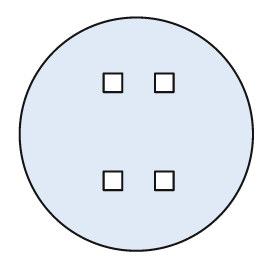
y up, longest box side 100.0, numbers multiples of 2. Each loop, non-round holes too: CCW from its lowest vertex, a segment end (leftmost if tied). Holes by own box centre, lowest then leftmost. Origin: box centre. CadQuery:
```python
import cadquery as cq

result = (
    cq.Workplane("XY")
    .moveTo(0.0, 0.0)
    .circle(50.0)
    .moveTo(-14.0, -24.0)
    .lineTo(-6.0, -24.0)
    .lineTo(-6.0, -16.0)
    .lineTo(-14.0, -16.0)
    .close()
    .moveTo(8.0, -24.0)
    .lineTo(16.0, -24.0)
    .lineTo(16.0, -16.0)
    .lineTo(8.0, -16.0)
    .close()
    .moveTo(-14.0, 18.0)
    .lineTo(-6.0, 18.0)
    .lineTo(-6.0, 26.0)
    .lineTo(-14.0, 26.0)
    .close()
    .moveTo(8.0, 18.0)
    .lineTo(16.0, 18.0)
    .lineTo(16.0, 26.0)
    .lineTo(8.0, 26.0)
    .close()
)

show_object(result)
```